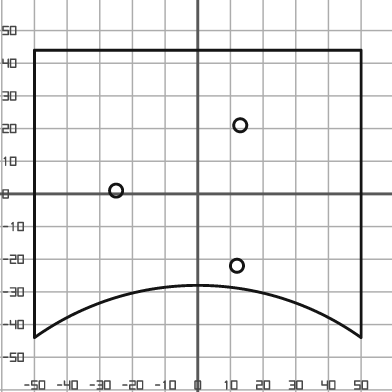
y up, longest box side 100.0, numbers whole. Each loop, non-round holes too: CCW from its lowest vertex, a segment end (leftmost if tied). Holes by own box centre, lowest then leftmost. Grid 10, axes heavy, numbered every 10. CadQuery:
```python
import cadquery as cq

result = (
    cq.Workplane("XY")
    .moveTo(-50.0, -44.0)
    .threePointArc((0.0, -28.0), (50.0, -44.0))
    .lineTo(50.0, 44.0)
    .lineTo(-50.0, 44.0)
    .close()
    .moveTo(12.0, -22.0)
    .circle(2.0)
    .moveTo(-25.0, 1.0)
    .circle(2.0)
    .moveTo(13.0, 21.0)
    .circle(2.0)
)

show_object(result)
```